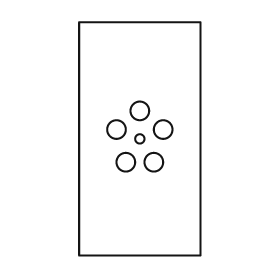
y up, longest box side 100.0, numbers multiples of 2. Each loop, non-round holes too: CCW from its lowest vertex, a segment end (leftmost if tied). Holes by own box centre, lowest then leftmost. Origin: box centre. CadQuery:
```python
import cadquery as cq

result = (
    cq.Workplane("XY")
    .moveTo(-26.0, -50.0)
    .lineTo(26.0, -50.0)
    .lineTo(26.0, 50.0)
    .lineTo(-26.0, 50.0)
    .close()
    .moveTo(-6.0, -10.0)
    .circle(4.0)
    .moveTo(6.0, -10.0)
    .circle(4.0)
    .moveTo(0.0, 0.0)
    .circle(2.0)
    .moveTo(-10.0, 4.0)
    .circle(4.0)
    .moveTo(10.0, 4.0)
    .circle(4.0)
    .moveTo(0.0, 12.0)
    .circle(4.0)
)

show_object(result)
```